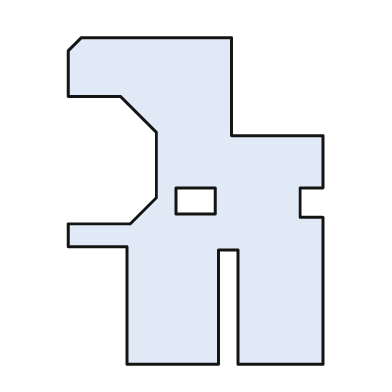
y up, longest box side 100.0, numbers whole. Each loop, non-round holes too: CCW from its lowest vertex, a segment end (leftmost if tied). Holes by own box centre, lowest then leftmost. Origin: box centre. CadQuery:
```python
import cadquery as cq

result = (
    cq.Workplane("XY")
    .moveTo(-21.0, -50.0)
    .lineTo(7.0, -50.0)
    .lineTo(7.0, -15.0)
    .lineTo(13.0, -15.0)
    .lineTo(13.0, -50.0)
    .lineTo(39.0, -50.0)
    .lineTo(39.0, -5.0)
    .lineTo(32.0, -5.0)
    .lineTo(32.0, 4.0)
    .lineTo(39.0, 4.0)
    .lineTo(39.0, 20.0)
    .lineTo(11.0, 20.0)
    .lineTo(11.0, 50.0)
    .lineTo(-35.0, 50.0)
    .lineTo(-39.0, 46.0)
    .lineTo(-39.0, 32.0)
    .lineTo(-23.0, 32.0)
    .lineTo(-12.0, 21.0)
    .lineTo(-12.0, 1.0)
    .lineTo(-20.0, -7.0)
    .lineTo(-39.0, -7.0)
    .lineTo(-39.0, -14.0)
    .lineTo(-21.0, -14.0)
    .close()
    .moveTo(-6.0, -4.0)
    .lineTo(6.0, -4.0)
    .lineTo(6.0, 4.0)
    .lineTo(-6.0, 4.0)
    .close()
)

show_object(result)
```